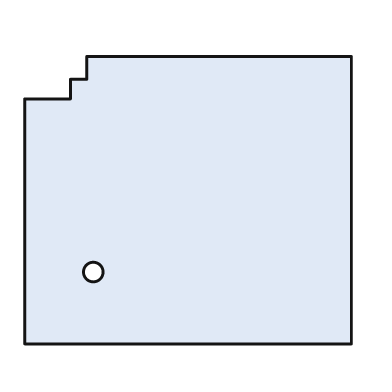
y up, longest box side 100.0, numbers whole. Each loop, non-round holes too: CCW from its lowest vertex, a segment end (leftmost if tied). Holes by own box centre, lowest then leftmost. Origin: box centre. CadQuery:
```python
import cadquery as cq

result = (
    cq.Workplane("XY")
    .moveTo(-50.0, -44.0)
    .lineTo(50.0, -44.0)
    .lineTo(50.0, 44.0)
    .lineTo(-31.0, 44.0)
    .lineTo(-31.0, 37.0)
    .lineTo(-36.0, 37.0)
    .lineTo(-36.0, 31.0)
    .lineTo(-50.0, 31.0)
    .close()
    .moveTo(-29.0, -22.0)
    .circle(3.0)
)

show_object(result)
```